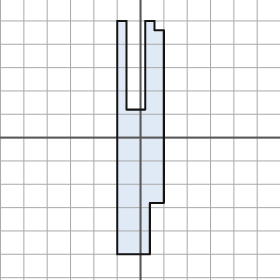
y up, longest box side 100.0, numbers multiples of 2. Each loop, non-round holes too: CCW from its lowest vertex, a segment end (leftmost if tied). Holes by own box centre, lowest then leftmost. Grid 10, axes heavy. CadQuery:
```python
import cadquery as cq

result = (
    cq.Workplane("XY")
    .moveTo(-10.0, -50.0)
    .lineTo(4.0, -50.0)
    .lineTo(4.0, -28.0)
    .lineTo(10.0, -28.0)
    .lineTo(10.0, 46.0)
    .lineTo(6.0, 46.0)
    .lineTo(6.0, 50.0)
    .lineTo(2.0, 50.0)
    .lineTo(2.0, 12.0)
    .lineTo(-6.0, 12.0)
    .lineTo(-6.0, 50.0)
    .lineTo(-10.0, 50.0)
    .close()
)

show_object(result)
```